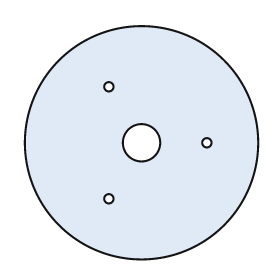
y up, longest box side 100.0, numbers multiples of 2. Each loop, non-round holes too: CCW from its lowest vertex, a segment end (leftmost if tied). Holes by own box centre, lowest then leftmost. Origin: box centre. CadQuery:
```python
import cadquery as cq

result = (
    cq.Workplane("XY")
    .moveTo(0.0, 0.0)
    .circle(50.0)
    .moveTo(-14.0, -24.0)
    .circle(2.0)
    .moveTo(0.0, 0.0)
    .circle(8.0)
    .moveTo(28.0, 0.0)
    .circle(2.0)
    .moveTo(-14.0, 24.0)
    .circle(2.0)
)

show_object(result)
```